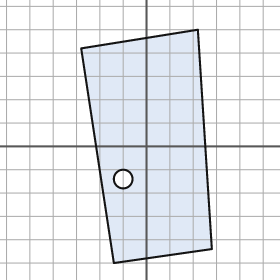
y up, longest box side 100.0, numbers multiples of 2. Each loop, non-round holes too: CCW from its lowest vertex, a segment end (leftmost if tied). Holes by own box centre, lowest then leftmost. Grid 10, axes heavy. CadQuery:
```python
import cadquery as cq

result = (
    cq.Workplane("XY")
    .moveTo(-14.0, -50.0)
    .lineTo(28.0, -44.0)
    .lineTo(22.0, 50.0)
    .lineTo(-28.0, 42.0)
    .close()
    .moveTo(-10.0, -14.0)
    .circle(4.0)
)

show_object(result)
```